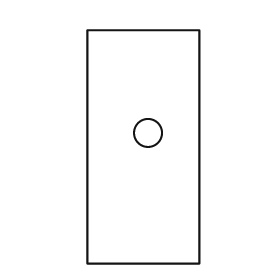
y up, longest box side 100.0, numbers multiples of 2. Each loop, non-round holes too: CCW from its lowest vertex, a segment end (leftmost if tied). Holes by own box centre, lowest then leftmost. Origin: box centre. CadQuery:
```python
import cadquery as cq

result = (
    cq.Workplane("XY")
    .moveTo(-24.0, -50.0)
    .lineTo(24.0, -50.0)
    .lineTo(24.0, 50.0)
    .lineTo(-24.0, 50.0)
    .close()
    .moveTo(2.0, 6.0)
    .circle(6.0)
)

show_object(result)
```